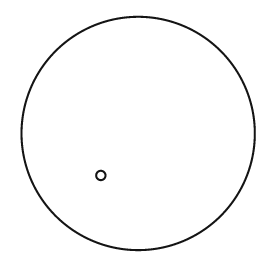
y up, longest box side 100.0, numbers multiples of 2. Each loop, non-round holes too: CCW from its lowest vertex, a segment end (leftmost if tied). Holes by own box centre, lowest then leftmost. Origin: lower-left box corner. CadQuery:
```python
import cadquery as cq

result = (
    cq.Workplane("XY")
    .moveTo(50.0, 50.0)
    .circle(50.0)
    .moveTo(34.0, 32.0)
    .circle(2.0)
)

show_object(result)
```